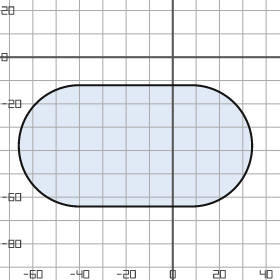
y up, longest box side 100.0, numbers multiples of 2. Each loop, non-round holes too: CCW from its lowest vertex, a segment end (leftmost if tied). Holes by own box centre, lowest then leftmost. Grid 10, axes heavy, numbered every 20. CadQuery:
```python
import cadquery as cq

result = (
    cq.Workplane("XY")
    .moveTo(-40.0, -64.0)
    .lineTo(8.0, -64.0)
    .threePointArc((34.0, -38.0), (8.0, -12.0))
    .lineTo(-40.0, -12.0)
    .threePointArc((-66.0, -38.0), (-40.0, -64.0))
    .close()
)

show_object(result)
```